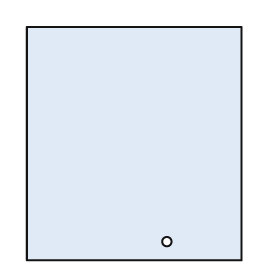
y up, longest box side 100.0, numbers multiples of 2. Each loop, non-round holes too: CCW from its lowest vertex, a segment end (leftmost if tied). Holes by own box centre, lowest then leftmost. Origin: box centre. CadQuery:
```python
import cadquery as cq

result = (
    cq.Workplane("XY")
    .moveTo(-46.0, -50.0)
    .lineTo(46.0, -50.0)
    .lineTo(46.0, 50.0)
    .lineTo(-46.0, 50.0)
    .close()
    .moveTo(14.0, -42.0)
    .circle(2.0)
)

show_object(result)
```